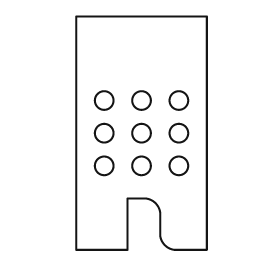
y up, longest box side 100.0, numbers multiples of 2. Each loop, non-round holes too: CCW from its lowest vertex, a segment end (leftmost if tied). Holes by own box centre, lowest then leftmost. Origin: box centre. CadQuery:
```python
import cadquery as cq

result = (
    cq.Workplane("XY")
    .moveTo(-28.0, -50.0)
    .lineTo(-6.0, -50.0)
    .lineTo(-6.0, -28.0)
    .lineTo(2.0, -28.0)
    .threePointArc((6.0, -30.0), (8.0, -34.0))
    .lineTo(8.0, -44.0)
    .threePointArc((10.0, -48.0), (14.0, -50.0))
    .lineTo(28.0, -50.0)
    .lineTo(28.0, 50.0)
    .lineTo(-28.0, 50.0)
    .close()
    .moveTo(-16.0, -14.0)
    .circle(4.0)
    .moveTo(0.0, -14.0)
    .circle(4.0)
    .moveTo(16.0, -14.0)
    .circle(4.0)
    .moveTo(-16.0, 0.0)
    .circle(4.0)
    .moveTo(0.0, 0.0)
    .circle(4.0)
    .moveTo(16.0, 0.0)
    .circle(4.0)
    .moveTo(-16.0, 14.0)
    .circle(4.0)
    .moveTo(0.0, 14.0)
    .circle(4.0)
    .moveTo(16.0, 14.0)
    .circle(4.0)
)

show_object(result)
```